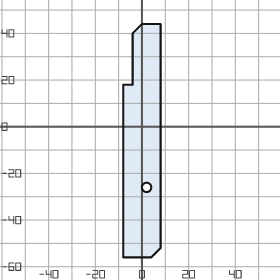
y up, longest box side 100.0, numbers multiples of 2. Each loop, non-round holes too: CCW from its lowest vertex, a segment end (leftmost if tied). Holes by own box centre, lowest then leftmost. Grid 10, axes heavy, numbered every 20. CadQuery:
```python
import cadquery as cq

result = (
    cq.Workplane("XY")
    .moveTo(-8.0, -56.0)
    .lineTo(4.0, -56.0)
    .lineTo(8.0, -52.0)
    .lineTo(8.0, 44.0)
    .lineTo(0.0, 44.0)
    .lineTo(-4.0, 40.0)
    .lineTo(-4.0, 18.0)
    .lineTo(-8.0, 18.0)
    .close()
    .moveTo(2.0, -26.0)
    .circle(2.0)
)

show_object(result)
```